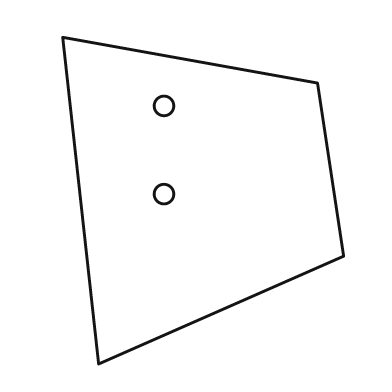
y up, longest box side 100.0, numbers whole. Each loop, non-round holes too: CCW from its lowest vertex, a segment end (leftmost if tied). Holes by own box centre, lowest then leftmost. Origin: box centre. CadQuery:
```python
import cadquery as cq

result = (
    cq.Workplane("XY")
    .moveTo(-32.0, -50.0)
    .lineTo(43.0, -17.0)
    .lineTo(35.0, 36.0)
    .lineTo(-43.0, 50.0)
    .close()
    .moveTo(-12.0, 2.0)
    .circle(3.0)
    .moveTo(-12.0, 29.0)
    .circle(3.0)
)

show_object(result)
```